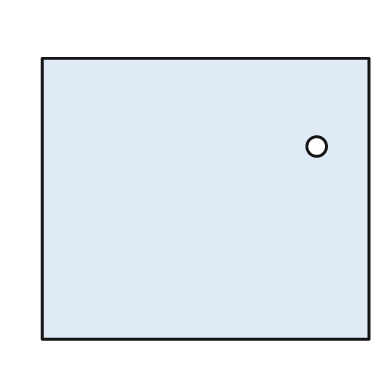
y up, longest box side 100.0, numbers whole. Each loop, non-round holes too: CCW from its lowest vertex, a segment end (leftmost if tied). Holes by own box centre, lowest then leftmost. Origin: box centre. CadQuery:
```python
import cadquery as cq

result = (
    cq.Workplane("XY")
    .moveTo(-50.0, -43.0)
    .lineTo(50.0, -43.0)
    .lineTo(50.0, 43.0)
    .lineTo(-50.0, 43.0)
    .close()
    .moveTo(34.0, 16.0)
    .circle(3.0)
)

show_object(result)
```